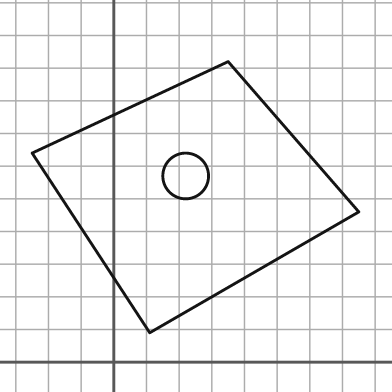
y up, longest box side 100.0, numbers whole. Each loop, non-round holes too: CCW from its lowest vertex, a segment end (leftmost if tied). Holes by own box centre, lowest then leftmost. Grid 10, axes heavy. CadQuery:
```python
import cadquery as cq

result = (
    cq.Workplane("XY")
    .moveTo(11.0, 9.0)
    .lineTo(75.0, 46.0)
    .lineTo(35.0, 92.0)
    .lineTo(-25.0, 64.0)
    .close()
    .moveTo(22.0, 57.0)
    .circle(7.0)
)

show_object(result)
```